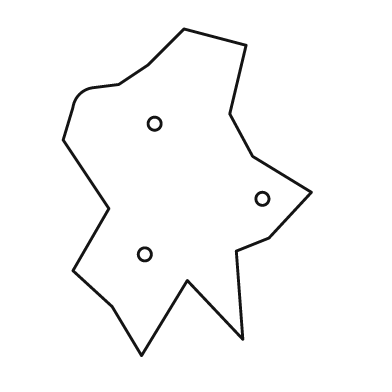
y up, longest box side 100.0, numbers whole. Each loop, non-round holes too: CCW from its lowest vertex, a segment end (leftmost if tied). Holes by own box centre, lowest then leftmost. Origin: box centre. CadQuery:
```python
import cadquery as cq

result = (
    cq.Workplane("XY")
    .moveTo(-14.0, -50.0)
    .lineTo(0.0, -27.0)
    .lineTo(17.0, -45.0)
    .lineTo(15.0, -18.0)
    .lineTo(25.0, -14.0)
    .lineTo(38.0, 0.0)
    .lineTo(20.0, 11.0)
    .lineTo(13.0, 24.0)
    .lineTo(18.0, 45.0)
    .lineTo(-1.0, 50.0)
    .lineTo(-12.0, 39.0)
    .lineTo(-21.0, 33.0)
    .lineTo(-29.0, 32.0)
    .threePointArc((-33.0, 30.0), (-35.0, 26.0))
    .lineTo(-38.0, 16.0)
    .lineTo(-24.0, -5.0)
    .lineTo(-35.0, -24.0)
    .lineTo(-23.0, -35.0)
    .close()
    .moveTo(-13.0, -19.0)
    .circle(2.0)
    .moveTo(23.0, -2.0)
    .circle(2.0)
    .moveTo(-10.0, 21.0)
    .circle(2.0)
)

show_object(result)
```